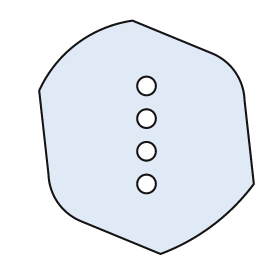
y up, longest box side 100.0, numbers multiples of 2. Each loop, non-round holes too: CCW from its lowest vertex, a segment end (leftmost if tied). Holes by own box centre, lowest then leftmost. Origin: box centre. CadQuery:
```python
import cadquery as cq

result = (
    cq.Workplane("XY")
    .moveTo(6.0, -50.0)
    .threePointArc((28.0, -38.0), (46.0, -20.0))
    .lineTo(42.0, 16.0)
    .threePointArc((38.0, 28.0), (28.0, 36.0))
    .lineTo(-6.0, 50.0)
    .threePointArc((-30.0, 40.0), (-46.0, 20.0))
    .lineTo(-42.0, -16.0)
    .threePointArc((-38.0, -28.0), (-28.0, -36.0))
    .close()
    .moveTo(0.0, -20.0)
    .circle(4.0)
    .moveTo(0.0, -6.0)
    .circle(4.0)
    .moveTo(0.0, 8.0)
    .circle(4.0)
    .moveTo(0.0, 22.0)
    .circle(4.0)
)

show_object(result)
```